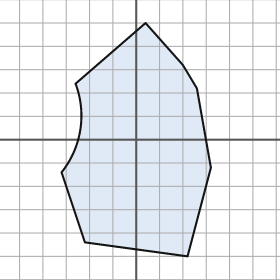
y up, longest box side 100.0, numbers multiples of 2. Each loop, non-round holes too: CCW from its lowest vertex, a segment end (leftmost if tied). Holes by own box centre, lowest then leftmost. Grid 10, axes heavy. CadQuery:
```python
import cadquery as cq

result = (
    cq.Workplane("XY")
    .moveTo(22.0, -50.0)
    .lineTo(32.0, -12.0)
    .lineTo(26.0, 22.0)
    .lineTo(20.0, 32.0)
    .lineTo(4.0, 50.0)
    .lineTo(-26.0, 24.0)
    .threePointArc((-24.0, 4.0), (-32.0, -14.0))
    .lineTo(-22.0, -44.0)
    .close()
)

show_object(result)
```